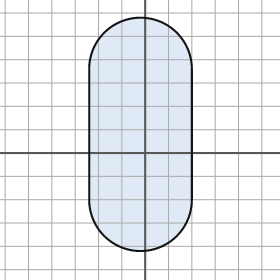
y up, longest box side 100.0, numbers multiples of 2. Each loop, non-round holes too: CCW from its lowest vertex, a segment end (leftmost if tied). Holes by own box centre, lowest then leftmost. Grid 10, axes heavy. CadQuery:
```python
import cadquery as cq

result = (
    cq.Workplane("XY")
    .moveTo(-24.0, -20.0)
    .threePointArc((-2.0, -42.0), (20.0, -20.0))
    .lineTo(20.0, 36.0)
    .threePointArc((-2.0, 58.0), (-24.0, 36.0))
    .close()
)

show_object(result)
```